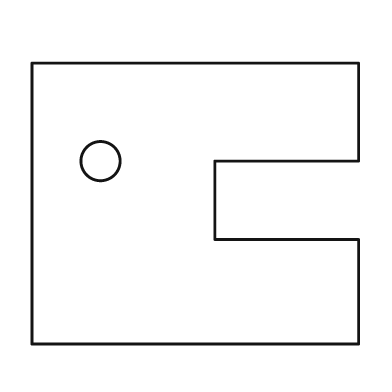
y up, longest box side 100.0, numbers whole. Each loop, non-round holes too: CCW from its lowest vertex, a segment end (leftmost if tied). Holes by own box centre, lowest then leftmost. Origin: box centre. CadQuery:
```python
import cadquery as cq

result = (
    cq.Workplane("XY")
    .moveTo(-50.0, -43.0)
    .lineTo(50.0, -43.0)
    .lineTo(50.0, -11.0)
    .lineTo(6.0, -11.0)
    .lineTo(6.0, 13.0)
    .lineTo(50.0, 13.0)
    .lineTo(50.0, 43.0)
    .lineTo(-50.0, 43.0)
    .close()
    .moveTo(-29.0, 13.0)
    .circle(6.0)
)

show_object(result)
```